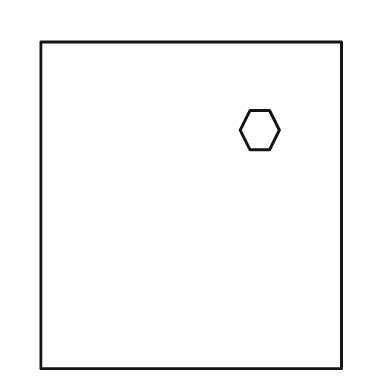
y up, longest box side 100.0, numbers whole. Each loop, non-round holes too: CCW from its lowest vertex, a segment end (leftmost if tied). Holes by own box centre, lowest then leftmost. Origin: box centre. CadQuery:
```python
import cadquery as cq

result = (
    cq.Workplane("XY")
    .moveTo(-46.0, -50.0)
    .lineTo(46.0, -50.0)
    .lineTo(46.0, 50.0)
    .lineTo(-46.0, 50.0)
    .close()
    .moveTo(18.0, 17.0)
    .lineTo(24.0, 17.0)
    .lineTo(27.0, 23.0)
    .lineTo(24.0, 29.0)
    .lineTo(18.0, 29.0)
    .lineTo(15.0, 23.0)
    .close()
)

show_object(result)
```